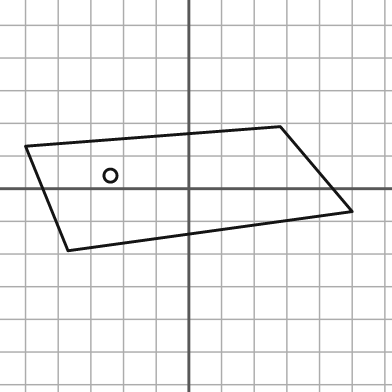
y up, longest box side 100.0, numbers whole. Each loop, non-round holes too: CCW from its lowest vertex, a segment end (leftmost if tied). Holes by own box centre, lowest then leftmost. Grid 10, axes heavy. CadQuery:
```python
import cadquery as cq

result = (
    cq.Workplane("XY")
    .moveTo(-37.0, -19.0)
    .lineTo(50.0, -7.0)
    .lineTo(28.0, 19.0)
    .lineTo(-50.0, 13.0)
    .close()
    .moveTo(-24.0, 4.0)
    .circle(2.0)
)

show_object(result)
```